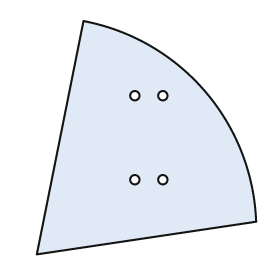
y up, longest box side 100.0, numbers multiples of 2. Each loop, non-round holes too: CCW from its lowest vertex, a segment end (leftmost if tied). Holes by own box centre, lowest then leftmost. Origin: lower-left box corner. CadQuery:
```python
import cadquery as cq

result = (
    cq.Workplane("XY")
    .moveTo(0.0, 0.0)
    .lineTo(94.0, 14.0)
    .threePointArc((72.0, 70.0), (20.0, 100.0))
    .close()
    .moveTo(42.0, 32.0)
    .circle(2.0)
    .moveTo(54.0, 32.0)
    .circle(2.0)
    .moveTo(42.0, 68.0)
    .circle(2.0)
    .moveTo(54.0, 68.0)
    .circle(2.0)
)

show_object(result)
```